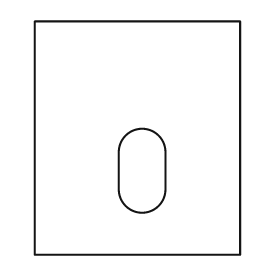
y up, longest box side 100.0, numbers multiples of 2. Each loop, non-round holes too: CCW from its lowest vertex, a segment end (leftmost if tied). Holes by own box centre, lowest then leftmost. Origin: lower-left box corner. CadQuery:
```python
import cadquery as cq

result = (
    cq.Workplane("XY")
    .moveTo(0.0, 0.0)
    .lineTo(88.0, 0.0)
    .lineTo(88.0, 100.0)
    .lineTo(0.0, 100.0)
    .close()
    .moveTo(36.0, 28.0)
    .threePointArc((46.0, 18.0), (56.0, 28.0))
    .lineTo(56.0, 44.0)
    .threePointArc((46.0, 54.0), (36.0, 44.0))
    .close()
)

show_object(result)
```